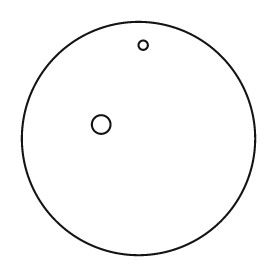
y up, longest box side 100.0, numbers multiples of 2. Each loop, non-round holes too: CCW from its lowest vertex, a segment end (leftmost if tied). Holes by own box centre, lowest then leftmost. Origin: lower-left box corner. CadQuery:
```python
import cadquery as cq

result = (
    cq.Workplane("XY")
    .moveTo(50.0, 50.0)
    .circle(50.0)
    .moveTo(34.0, 56.0)
    .circle(4.0)
    .moveTo(52.0, 90.0)
    .circle(2.0)
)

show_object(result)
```